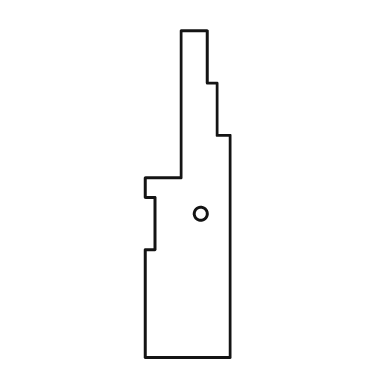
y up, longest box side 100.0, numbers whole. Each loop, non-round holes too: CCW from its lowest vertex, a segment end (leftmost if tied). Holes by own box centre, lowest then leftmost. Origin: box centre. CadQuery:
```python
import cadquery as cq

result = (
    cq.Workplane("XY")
    .moveTo(-13.0, -50.0)
    .lineTo(13.0, -50.0)
    .lineTo(13.0, 18.0)
    .lineTo(9.0, 18.0)
    .lineTo(9.0, 34.0)
    .lineTo(6.0, 34.0)
    .lineTo(6.0, 50.0)
    .lineTo(-2.0, 50.0)
    .lineTo(-2.0, 5.0)
    .lineTo(-13.0, 5.0)
    .lineTo(-13.0, -1.0)
    .lineTo(-10.0, -1.0)
    .lineTo(-10.0, -17.0)
    .lineTo(-13.0, -17.0)
    .close()
    .moveTo(4.0, -6.0)
    .circle(2.0)
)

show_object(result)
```